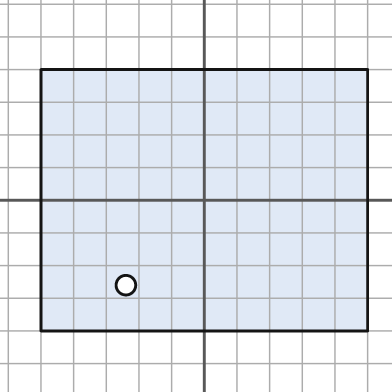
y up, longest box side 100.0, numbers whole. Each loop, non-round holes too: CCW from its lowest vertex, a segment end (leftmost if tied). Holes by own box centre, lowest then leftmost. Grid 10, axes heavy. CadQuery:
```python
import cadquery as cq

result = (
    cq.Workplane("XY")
    .moveTo(-50.0, -40.0)
    .lineTo(50.0, -40.0)
    .lineTo(50.0, 40.0)
    .lineTo(-50.0, 40.0)
    .close()
    .moveTo(-24.0, -26.0)
    .circle(3.0)
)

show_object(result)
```